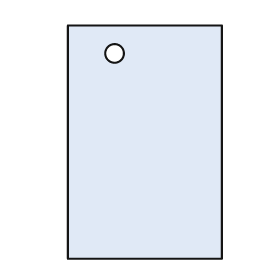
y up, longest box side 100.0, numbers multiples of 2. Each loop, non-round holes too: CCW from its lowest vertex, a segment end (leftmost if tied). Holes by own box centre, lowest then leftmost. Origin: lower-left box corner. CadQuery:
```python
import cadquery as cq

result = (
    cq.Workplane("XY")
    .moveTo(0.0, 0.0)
    .lineTo(66.0, 0.0)
    .lineTo(66.0, 100.0)
    .lineTo(0.0, 100.0)
    .close()
    .moveTo(20.0, 88.0)
    .circle(4.0)
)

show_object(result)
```